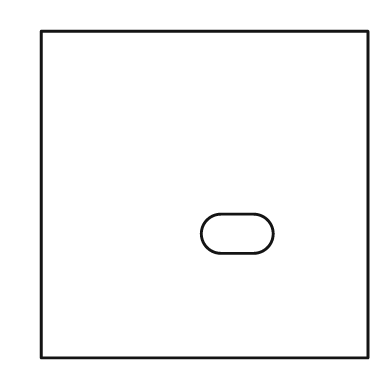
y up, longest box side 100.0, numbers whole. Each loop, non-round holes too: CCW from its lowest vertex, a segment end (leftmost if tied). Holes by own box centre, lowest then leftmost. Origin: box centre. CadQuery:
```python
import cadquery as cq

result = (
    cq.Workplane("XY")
    .moveTo(-50.0, -50.0)
    .lineTo(50.0, -50.0)
    .lineTo(50.0, 50.0)
    .lineTo(-50.0, 50.0)
    .close()
    .moveTo(5.0, -18.0)
    .lineTo(15.0, -18.0)
    .threePointArc((21.0, -12.0), (15.0, -6.0))
    .lineTo(5.0, -6.0)
    .threePointArc((-1.0, -12.0), (5.0, -18.0))
    .close()
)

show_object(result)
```